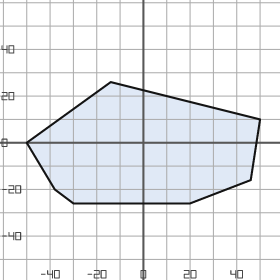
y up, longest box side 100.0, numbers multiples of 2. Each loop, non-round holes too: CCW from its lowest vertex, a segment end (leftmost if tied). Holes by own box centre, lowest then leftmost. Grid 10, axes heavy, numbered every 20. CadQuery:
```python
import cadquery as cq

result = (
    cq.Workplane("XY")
    .moveTo(-30.0, -26.0)
    .lineTo(20.0, -26.0)
    .lineTo(46.0, -16.0)
    .lineTo(50.0, 10.0)
    .lineTo(-14.0, 26.0)
    .lineTo(-50.0, 0.0)
    .lineTo(-38.0, -20.0)
    .close()
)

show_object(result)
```